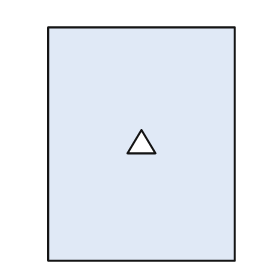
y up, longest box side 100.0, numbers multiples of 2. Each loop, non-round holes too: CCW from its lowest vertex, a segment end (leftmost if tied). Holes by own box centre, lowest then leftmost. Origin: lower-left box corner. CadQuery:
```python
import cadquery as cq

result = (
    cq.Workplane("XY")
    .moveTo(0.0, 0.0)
    .lineTo(80.0, 0.0)
    .lineTo(80.0, 100.0)
    .lineTo(0.0, 100.0)
    .close()
    .moveTo(34.0, 46.0)
    .lineTo(46.0, 46.0)
    .lineTo(40.0, 56.0)
    .close()
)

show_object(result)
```